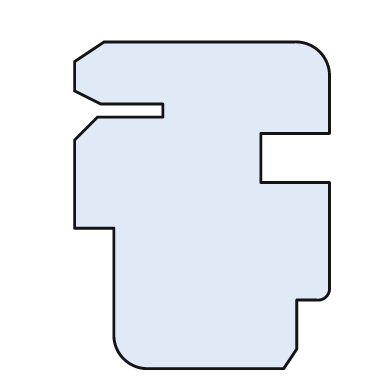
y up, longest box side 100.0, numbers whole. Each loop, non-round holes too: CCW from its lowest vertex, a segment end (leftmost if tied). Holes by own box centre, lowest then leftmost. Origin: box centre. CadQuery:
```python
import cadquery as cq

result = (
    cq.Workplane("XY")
    .moveTo(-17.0, -50.0)
    .lineTo(25.0, -50.0)
    .lineTo(29.0, -44.0)
    .lineTo(29.0, -29.0)
    .lineTo(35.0, -29.0)
    .threePointArc((38.0, -28.0), (39.0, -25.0))
    .lineTo(39.0, 7.0)
    .lineTo(18.0, 7.0)
    .lineTo(18.0, 22.0)
    .lineTo(39.0, 22.0)
    .lineTo(39.0, 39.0)
    .threePointArc((36.0, 47.0), (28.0, 50.0))
    .lineTo(-30.0, 50.0)
    .lineTo(-39.0, 44.0)
    .lineTo(-39.0, 35.0)
    .lineTo(-31.0, 31.0)
    .lineTo(-12.0, 31.0)
    .lineTo(-12.0, 27.0)
    .lineTo(-32.0, 27.0)
    .lineTo(-39.0, 20.0)
    .lineTo(-39.0, -7.0)
    .lineTo(-27.0, -7.0)
    .lineTo(-27.0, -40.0)
    .threePointArc((-24.0, -47.0), (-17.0, -50.0))
    .close()
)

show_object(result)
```